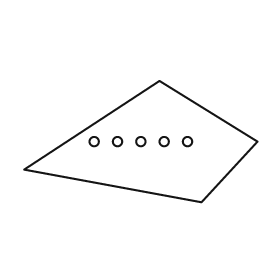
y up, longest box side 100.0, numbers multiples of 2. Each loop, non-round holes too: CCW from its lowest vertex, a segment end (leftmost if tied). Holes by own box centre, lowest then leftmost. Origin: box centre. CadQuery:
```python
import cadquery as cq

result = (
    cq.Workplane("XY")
    .moveTo(26.0, -26.0)
    .lineTo(50.0, 0.0)
    .lineTo(8.0, 26.0)
    .lineTo(-50.0, -12.0)
    .close()
    .moveTo(-20.0, 0.0)
    .circle(2.0)
    .moveTo(-10.0, 0.0)
    .circle(2.0)
    .moveTo(0.0, 0.0)
    .circle(2.0)
    .moveTo(10.0, 0.0)
    .circle(2.0)
    .moveTo(20.0, 0.0)
    .circle(2.0)
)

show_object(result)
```